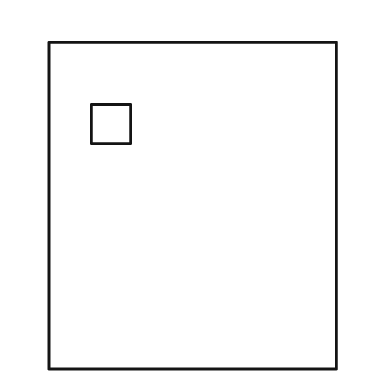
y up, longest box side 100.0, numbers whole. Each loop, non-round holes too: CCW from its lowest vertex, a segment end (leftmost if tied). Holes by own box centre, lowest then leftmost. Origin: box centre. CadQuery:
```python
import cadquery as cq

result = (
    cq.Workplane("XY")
    .moveTo(-44.0, -50.0)
    .lineTo(44.0, -50.0)
    .lineTo(44.0, 50.0)
    .lineTo(-44.0, 50.0)
    .close()
    .moveTo(-31.0, 19.0)
    .lineTo(-19.0, 19.0)
    .lineTo(-19.0, 31.0)
    .lineTo(-31.0, 31.0)
    .close()
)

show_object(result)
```